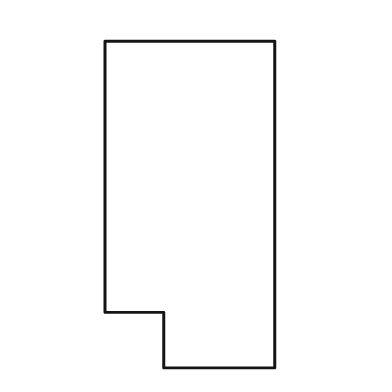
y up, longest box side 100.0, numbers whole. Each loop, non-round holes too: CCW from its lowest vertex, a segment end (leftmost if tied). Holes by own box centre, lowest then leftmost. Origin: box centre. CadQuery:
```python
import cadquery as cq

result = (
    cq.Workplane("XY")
    .moveTo(-8.0, -50.0)
    .lineTo(26.0, -50.0)
    .lineTo(26.0, 50.0)
    .lineTo(-26.0, 50.0)
    .lineTo(-26.0, -33.0)
    .lineTo(-8.0, -33.0)
    .close()
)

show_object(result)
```